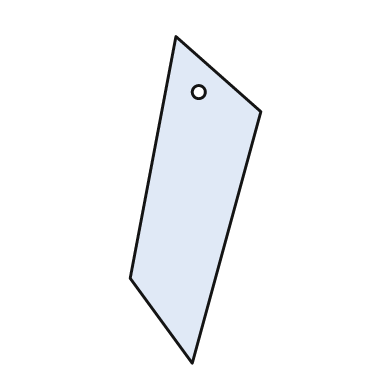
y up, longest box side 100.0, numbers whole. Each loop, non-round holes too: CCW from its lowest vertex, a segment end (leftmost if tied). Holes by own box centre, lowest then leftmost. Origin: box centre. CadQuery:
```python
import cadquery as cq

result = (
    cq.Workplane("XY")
    .moveTo(-1.0, -50.0)
    .lineTo(20.0, 27.0)
    .lineTo(-6.0, 50.0)
    .lineTo(-20.0, -24.0)
    .close()
    .moveTo(1.0, 33.0)
    .circle(2.0)
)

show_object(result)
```